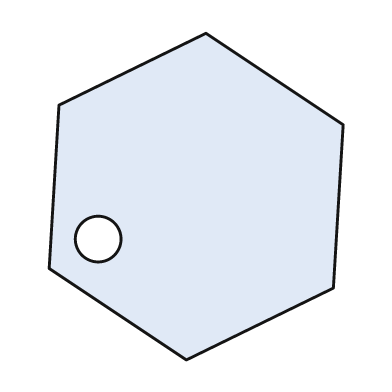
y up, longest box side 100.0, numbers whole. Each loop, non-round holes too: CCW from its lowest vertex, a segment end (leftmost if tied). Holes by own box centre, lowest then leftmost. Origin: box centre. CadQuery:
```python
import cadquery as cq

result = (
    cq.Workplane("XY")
    .moveTo(-3.0, -50.0)
    .lineTo(42.0, -28.0)
    .lineTo(45.0, 22.0)
    .lineTo(3.0, 50.0)
    .lineTo(-42.0, 28.0)
    .lineTo(-45.0, -22.0)
    .close()
    .moveTo(-30.0, -13.0)
    .circle(7.0)
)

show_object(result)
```